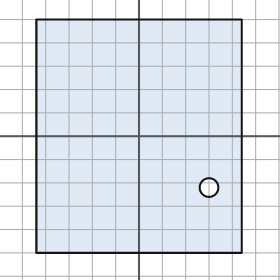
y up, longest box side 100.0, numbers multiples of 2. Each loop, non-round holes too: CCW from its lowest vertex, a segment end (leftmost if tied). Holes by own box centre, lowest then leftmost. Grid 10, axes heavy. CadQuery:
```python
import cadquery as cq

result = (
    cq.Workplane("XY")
    .moveTo(-44.0, -50.0)
    .lineTo(44.0, -50.0)
    .lineTo(44.0, 50.0)
    .lineTo(-44.0, 50.0)
    .close()
    .moveTo(30.0, -22.0)
    .circle(4.0)
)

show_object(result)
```